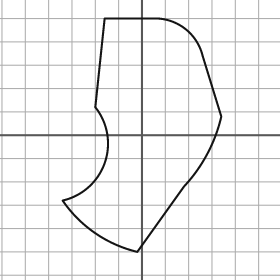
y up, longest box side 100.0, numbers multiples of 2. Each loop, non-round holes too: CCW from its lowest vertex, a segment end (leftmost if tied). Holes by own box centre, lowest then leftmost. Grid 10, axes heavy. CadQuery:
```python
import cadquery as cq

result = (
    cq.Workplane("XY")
    .moveTo(-2.0, -50.0)
    .lineTo(18.0, -22.0)
    .threePointArc((28.0, -8.0), (34.0, 8.0))
    .lineTo(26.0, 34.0)
    .threePointArc((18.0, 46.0), (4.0, 50.0))
    .lineTo(-16.0, 50.0)
    .lineTo(-20.0, 12.0)
    .threePointArc((-16.0, -12.0), (-34.0, -28.0))
    .threePointArc((-20.0, -42.0), (-2.0, -50.0))
    .close()
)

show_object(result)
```